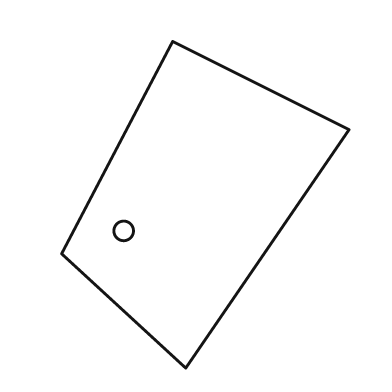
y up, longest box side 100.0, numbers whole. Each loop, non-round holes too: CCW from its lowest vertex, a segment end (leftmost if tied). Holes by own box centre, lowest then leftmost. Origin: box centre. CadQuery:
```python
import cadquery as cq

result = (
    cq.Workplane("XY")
    .moveTo(-6.0, -50.0)
    .lineTo(44.0, 23.0)
    .lineTo(-10.0, 50.0)
    .lineTo(-44.0, -15.0)
    .close()
    .moveTo(-25.0, -8.0)
    .circle(3.0)
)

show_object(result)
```